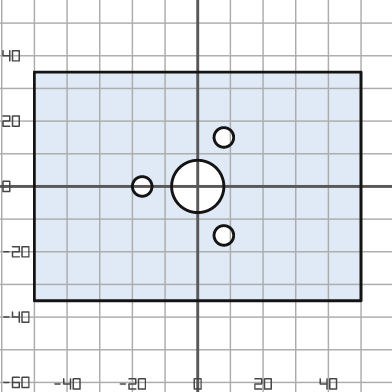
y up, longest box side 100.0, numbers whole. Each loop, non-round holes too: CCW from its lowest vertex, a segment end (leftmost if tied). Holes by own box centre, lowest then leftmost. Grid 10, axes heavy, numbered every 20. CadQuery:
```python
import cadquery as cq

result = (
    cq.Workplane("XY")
    .moveTo(-50.0, -35.0)
    .lineTo(50.0, -35.0)
    .lineTo(50.0, 35.0)
    .lineTo(-50.0, 35.0)
    .close()
    .moveTo(8.0, -15.0)
    .circle(3.0)
    .moveTo(-17.0, 0.0)
    .circle(3.0)
    .moveTo(0.0, 0.0)
    .circle(8.0)
    .moveTo(8.0, 15.0)
    .circle(3.0)
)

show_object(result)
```